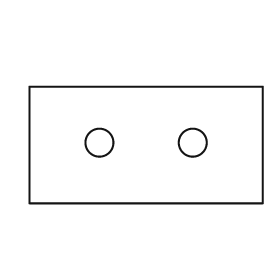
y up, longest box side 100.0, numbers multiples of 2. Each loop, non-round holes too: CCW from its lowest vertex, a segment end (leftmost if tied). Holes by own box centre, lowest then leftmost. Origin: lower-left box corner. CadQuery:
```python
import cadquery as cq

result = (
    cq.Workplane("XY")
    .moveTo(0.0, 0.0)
    .lineTo(100.0, 0.0)
    .lineTo(100.0, 50.0)
    .lineTo(0.0, 50.0)
    .close()
    .moveTo(30.0, 26.0)
    .circle(6.0)
    .moveTo(70.0, 26.0)
    .circle(6.0)
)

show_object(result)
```